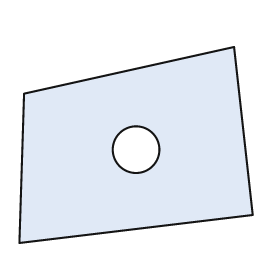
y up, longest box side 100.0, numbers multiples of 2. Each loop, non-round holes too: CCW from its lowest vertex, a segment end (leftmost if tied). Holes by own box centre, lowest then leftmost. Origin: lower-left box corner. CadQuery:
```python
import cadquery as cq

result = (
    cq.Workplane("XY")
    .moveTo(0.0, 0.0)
    .lineTo(100.0, 12.0)
    .lineTo(92.0, 84.0)
    .lineTo(2.0, 64.0)
    .close()
    .moveTo(50.0, 40.0)
    .circle(10.0)
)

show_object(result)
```